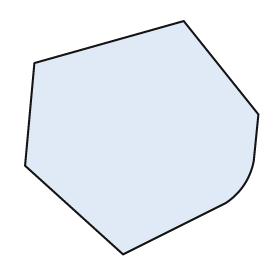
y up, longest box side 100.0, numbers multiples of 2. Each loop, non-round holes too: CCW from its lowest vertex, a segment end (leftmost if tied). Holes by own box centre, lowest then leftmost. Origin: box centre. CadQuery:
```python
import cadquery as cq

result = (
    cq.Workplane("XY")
    .moveTo(-8.0, -50.0)
    .lineTo(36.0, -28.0)
    .threePointArc((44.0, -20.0), (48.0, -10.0))
    .lineTo(50.0, 10.0)
    .lineTo(18.0, 50.0)
    .lineTo(-46.0, 32.0)
    .lineTo(-50.0, -12.0)
    .close()
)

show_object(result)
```